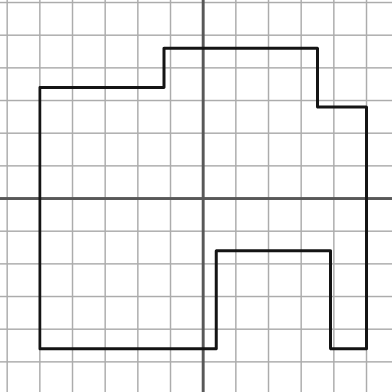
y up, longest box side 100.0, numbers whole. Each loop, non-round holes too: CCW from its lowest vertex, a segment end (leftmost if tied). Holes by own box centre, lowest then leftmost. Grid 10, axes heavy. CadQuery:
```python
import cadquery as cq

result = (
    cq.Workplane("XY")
    .moveTo(-50.0, -46.0)
    .lineTo(4.0, -46.0)
    .lineTo(4.0, -16.0)
    .lineTo(39.0, -16.0)
    .lineTo(39.0, -46.0)
    .lineTo(50.0, -46.0)
    .lineTo(50.0, 28.0)
    .lineTo(35.0, 28.0)
    .lineTo(35.0, 46.0)
    .lineTo(-12.0, 46.0)
    .lineTo(-12.0, 34.0)
    .lineTo(-50.0, 34.0)
    .close()
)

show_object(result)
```